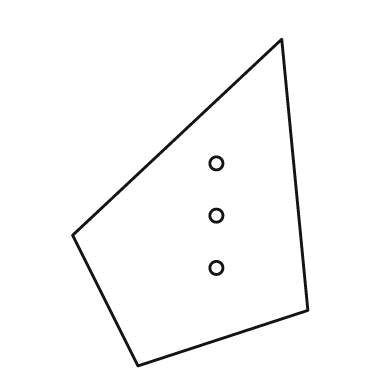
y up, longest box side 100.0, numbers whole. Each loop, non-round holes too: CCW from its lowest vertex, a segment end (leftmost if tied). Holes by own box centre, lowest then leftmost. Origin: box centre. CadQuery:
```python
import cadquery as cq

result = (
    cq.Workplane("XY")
    .moveTo(-16.0, -50.0)
    .lineTo(36.0, -33.0)
    .lineTo(28.0, 50.0)
    .lineTo(-36.0, -10.0)
    .close()
    .moveTo(8.0, -20.0)
    .circle(2.0)
    .moveTo(8.0, -4.0)
    .circle(2.0)
    .moveTo(8.0, 12.0)
    .circle(2.0)
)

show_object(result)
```